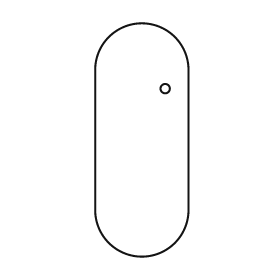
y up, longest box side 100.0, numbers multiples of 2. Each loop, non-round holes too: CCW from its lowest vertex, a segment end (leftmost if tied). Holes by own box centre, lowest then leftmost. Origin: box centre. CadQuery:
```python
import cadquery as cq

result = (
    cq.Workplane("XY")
    .moveTo(-20.0, -30.0)
    .threePointArc((0.0, -50.0), (20.0, -30.0))
    .lineTo(20.0, 30.0)
    .threePointArc((0.0, 50.0), (-20.0, 30.0))
    .close()
    .moveTo(10.0, 22.0)
    .circle(2.0)
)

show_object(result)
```